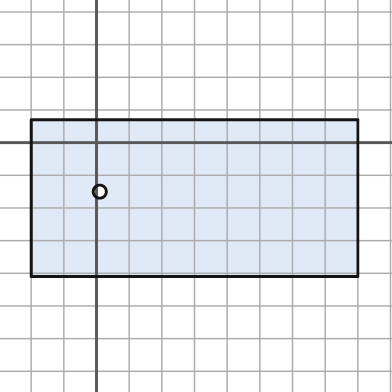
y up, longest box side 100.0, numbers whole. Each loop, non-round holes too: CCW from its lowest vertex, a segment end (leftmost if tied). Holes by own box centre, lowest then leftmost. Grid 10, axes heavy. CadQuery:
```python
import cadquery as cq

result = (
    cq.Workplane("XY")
    .moveTo(-20.0, -41.0)
    .lineTo(80.0, -41.0)
    .lineTo(80.0, 7.0)
    .lineTo(-20.0, 7.0)
    .close()
    .moveTo(1.0, -15.0)
    .circle(2.0)
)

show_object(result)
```